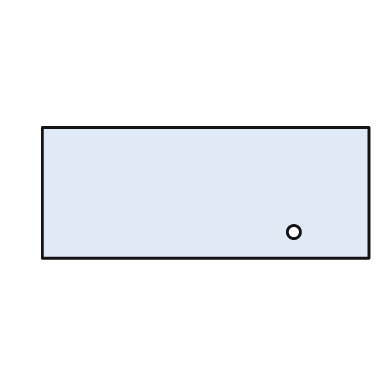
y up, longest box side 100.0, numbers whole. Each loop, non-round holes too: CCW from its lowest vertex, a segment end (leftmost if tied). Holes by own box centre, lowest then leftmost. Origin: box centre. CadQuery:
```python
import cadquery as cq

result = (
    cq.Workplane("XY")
    .moveTo(-50.0, -20.0)
    .lineTo(50.0, -20.0)
    .lineTo(50.0, 20.0)
    .lineTo(-50.0, 20.0)
    .close()
    .moveTo(27.0, -12.0)
    .circle(2.0)
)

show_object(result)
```